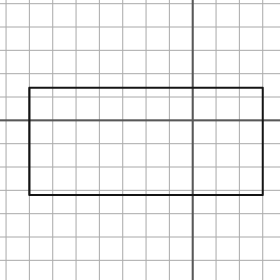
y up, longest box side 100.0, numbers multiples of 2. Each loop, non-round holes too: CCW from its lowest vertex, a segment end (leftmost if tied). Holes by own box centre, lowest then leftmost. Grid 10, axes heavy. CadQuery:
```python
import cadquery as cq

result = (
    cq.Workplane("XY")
    .moveTo(-70.0, -32.0)
    .lineTo(30.0, -32.0)
    .lineTo(30.0, 14.0)
    .lineTo(-70.0, 14.0)
    .close()
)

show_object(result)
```